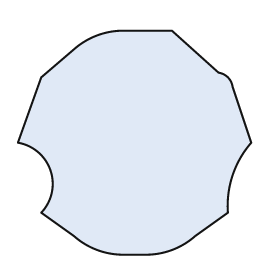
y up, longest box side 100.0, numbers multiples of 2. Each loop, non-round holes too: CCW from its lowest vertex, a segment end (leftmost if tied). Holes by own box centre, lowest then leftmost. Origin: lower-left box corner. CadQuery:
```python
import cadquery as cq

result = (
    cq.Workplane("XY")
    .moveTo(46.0, 0.0)
    .lineTo(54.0, 0.0)
    .threePointArc((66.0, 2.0), (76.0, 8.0))
    .lineTo(90.0, 18.0)
    .threePointArc((92.0, 34.0), (100.0, 48.0))
    .lineTo(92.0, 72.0)
    .threePointArc((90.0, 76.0), (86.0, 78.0))
    .lineTo(66.0, 96.0)
    .lineTo(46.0, 96.0)
    .threePointArc((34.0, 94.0), (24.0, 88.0))
    .lineTo(10.0, 76.0)
    .lineTo(0.0, 48.0)
    .threePointArc((14.0, 36.0), (10.0, 18.0))
    .lineTo(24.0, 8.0)
    .threePointArc((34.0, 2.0), (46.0, 0.0))
    .close()
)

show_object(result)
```